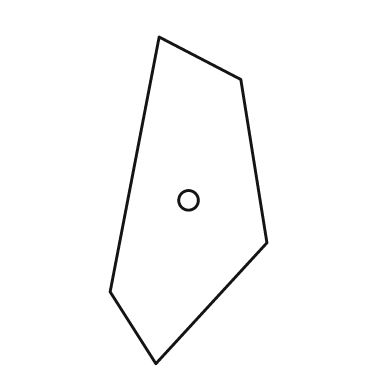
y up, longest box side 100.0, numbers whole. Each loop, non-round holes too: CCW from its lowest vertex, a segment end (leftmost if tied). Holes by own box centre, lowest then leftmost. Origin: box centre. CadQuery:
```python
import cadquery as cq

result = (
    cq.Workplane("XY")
    .moveTo(-10.0, -50.0)
    .lineTo(24.0, -13.0)
    .lineTo(16.0, 37.0)
    .lineTo(-9.0, 50.0)
    .lineTo(-24.0, -28.0)
    .close()
    .moveTo(0.0, 0.0)
    .circle(3.0)
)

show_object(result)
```